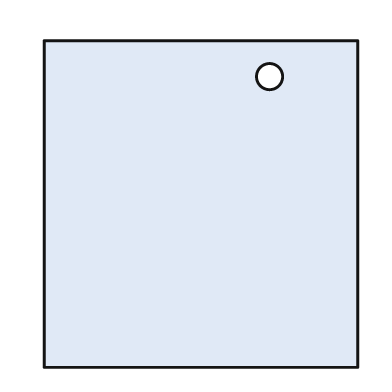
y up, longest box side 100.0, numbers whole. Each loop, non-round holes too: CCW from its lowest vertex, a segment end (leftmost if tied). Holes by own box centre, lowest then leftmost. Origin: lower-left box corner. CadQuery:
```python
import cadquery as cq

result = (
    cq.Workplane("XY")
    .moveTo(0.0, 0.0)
    .lineTo(96.0, 0.0)
    .lineTo(96.0, 100.0)
    .lineTo(0.0, 100.0)
    .close()
    .moveTo(69.0, 89.0)
    .circle(4.0)
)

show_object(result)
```